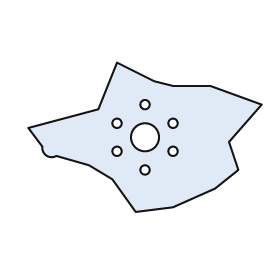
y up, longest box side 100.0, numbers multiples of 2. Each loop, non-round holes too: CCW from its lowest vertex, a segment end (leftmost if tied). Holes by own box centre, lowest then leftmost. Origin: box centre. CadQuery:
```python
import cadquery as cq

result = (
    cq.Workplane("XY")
    .moveTo(-4.0, -32.0)
    .lineTo(12.0, -30.0)
    .lineTo(30.0, -22.0)
    .lineTo(40.0, -14.0)
    .lineTo(36.0, -2.0)
    .lineTo(50.0, 14.0)
    .lineTo(28.0, 22.0)
    .lineTo(12.0, 22.0)
    .lineTo(4.0, 24.0)
    .lineTo(-12.0, 32.0)
    .lineTo(-20.0, 12.0)
    .lineTo(-50.0, 4.0)
    .lineTo(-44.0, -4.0)
    .threePointArc((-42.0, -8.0), (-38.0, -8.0))
    .lineTo(-24.0, -12.0)
    .lineTo(-14.0, -18.0)
    .close()
    .moveTo(0.0, -14.0)
    .circle(2.0)
    .moveTo(-12.0, -6.0)
    .circle(2.0)
    .moveTo(12.0, -6.0)
    .circle(2.0)
    .moveTo(0.0, 0.0)
    .circle(6.0)
    .moveTo(-12.0, 6.0)
    .circle(2.0)
    .moveTo(12.0, 6.0)
    .circle(2.0)
    .moveTo(0.0, 14.0)
    .circle(2.0)
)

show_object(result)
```